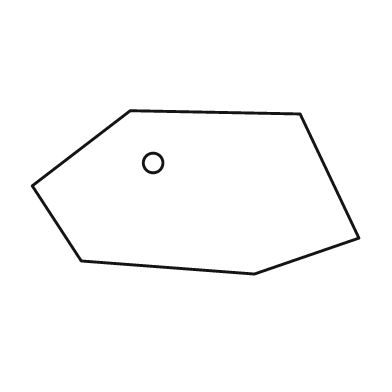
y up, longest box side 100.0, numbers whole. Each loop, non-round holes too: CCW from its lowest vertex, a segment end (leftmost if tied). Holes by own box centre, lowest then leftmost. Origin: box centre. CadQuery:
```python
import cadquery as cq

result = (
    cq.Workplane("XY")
    .moveTo(18.0, -25.0)
    .lineTo(50.0, -14.0)
    .lineTo(32.0, 24.0)
    .lineTo(-20.0, 25.0)
    .lineTo(-50.0, 2.0)
    .lineTo(-35.0, -21.0)
    .close()
    .moveTo(-13.0, 9.0)
    .circle(3.0)
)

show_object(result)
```